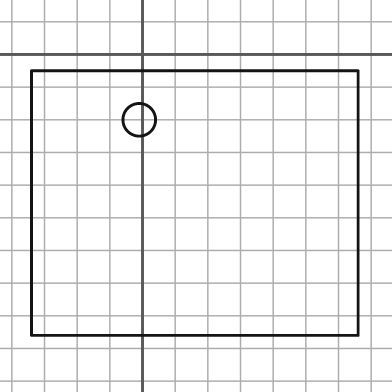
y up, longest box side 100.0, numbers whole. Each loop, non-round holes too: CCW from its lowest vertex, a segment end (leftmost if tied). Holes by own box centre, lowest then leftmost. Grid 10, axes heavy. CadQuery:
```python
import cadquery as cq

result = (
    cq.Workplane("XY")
    .moveTo(-34.0, -86.0)
    .lineTo(66.0, -86.0)
    .lineTo(66.0, -5.0)
    .lineTo(-34.0, -5.0)
    .close()
    .moveTo(-1.0, -20.0)
    .circle(5.0)
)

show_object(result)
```